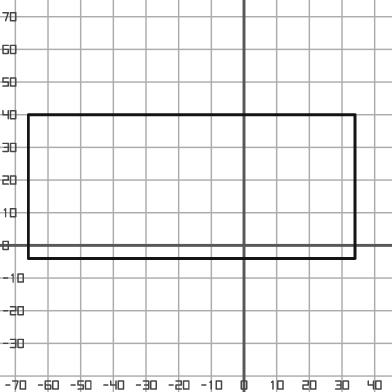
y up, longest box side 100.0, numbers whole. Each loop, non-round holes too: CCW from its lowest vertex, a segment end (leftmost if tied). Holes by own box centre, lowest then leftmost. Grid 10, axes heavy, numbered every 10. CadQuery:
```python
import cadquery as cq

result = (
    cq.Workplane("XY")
    .moveTo(-66.0, -4.0)
    .lineTo(34.0, -4.0)
    .lineTo(34.0, 40.0)
    .lineTo(-66.0, 40.0)
    .close()
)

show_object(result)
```